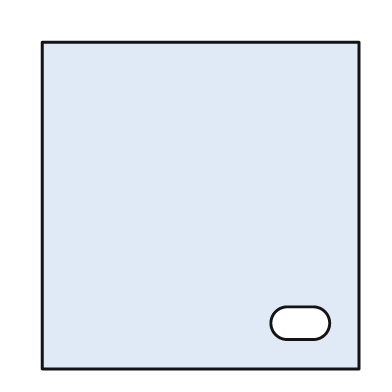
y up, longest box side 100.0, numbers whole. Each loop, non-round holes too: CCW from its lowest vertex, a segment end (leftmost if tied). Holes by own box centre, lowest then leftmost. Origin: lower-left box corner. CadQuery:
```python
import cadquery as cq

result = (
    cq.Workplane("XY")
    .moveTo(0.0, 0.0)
    .lineTo(97.0, 0.0)
    .lineTo(97.0, 100.0)
    .lineTo(0.0, 100.0)
    .close()
    .moveTo(75.0, 9.0)
    .lineTo(83.0, 9.0)
    .threePointArc((88.0, 14.0), (83.0, 19.0))
    .lineTo(75.0, 19.0)
    .threePointArc((70.0, 14.0), (75.0, 9.0))
    .close()
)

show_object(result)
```